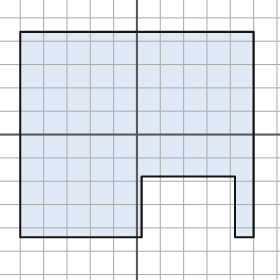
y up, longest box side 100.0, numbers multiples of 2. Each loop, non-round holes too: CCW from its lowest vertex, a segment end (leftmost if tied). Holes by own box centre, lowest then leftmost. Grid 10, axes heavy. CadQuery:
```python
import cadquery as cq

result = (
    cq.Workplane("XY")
    .moveTo(-50.0, -44.0)
    .lineTo(2.0, -44.0)
    .lineTo(2.0, -18.0)
    .lineTo(42.0, -18.0)
    .lineTo(42.0, -44.0)
    .lineTo(50.0, -44.0)
    .lineTo(50.0, 44.0)
    .lineTo(-50.0, 44.0)
    .close()
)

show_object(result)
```